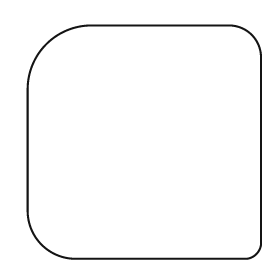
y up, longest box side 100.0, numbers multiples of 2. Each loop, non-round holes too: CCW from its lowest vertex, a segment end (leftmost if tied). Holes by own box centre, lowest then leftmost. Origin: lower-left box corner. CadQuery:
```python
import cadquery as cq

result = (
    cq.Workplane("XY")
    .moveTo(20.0, 0.0)
    .lineTo(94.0, 0.0)
    .threePointArc((98.0, 2.0), (100.0, 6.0))
    .lineTo(100.0, 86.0)
    .threePointArc((96.0, 96.0), (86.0, 100.0))
    .lineTo(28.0, 100.0)
    .threePointArc((8.0, 92.0), (0.0, 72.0))
    .lineTo(0.0, 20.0)
    .threePointArc((6.0, 6.0), (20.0, 0.0))
    .close()
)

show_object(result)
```